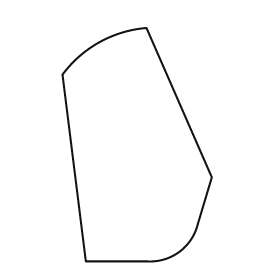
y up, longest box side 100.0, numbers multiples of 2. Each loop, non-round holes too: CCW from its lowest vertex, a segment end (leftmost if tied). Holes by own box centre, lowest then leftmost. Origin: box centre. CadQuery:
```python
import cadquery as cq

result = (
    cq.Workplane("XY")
    .moveTo(-22.0, -50.0)
    .lineTo(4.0, -50.0)
    .threePointArc((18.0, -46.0), (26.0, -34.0))
    .lineTo(32.0, -14.0)
    .lineTo(4.0, 50.0)
    .threePointArc((-16.0, 44.0), (-32.0, 30.0))
    .close()
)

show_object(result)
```